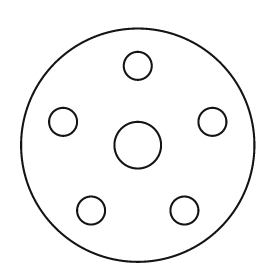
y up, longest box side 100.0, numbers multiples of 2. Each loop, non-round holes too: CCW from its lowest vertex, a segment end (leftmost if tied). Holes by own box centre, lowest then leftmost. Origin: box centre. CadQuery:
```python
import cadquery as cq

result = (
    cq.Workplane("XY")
    .moveTo(0.0, 0.0)
    .circle(50.0)
    .moveTo(-20.0, -28.0)
    .circle(6.0)
    .moveTo(20.0, -28.0)
    .circle(6.0)
    .moveTo(0.0, 0.0)
    .circle(10.0)
    .moveTo(-32.0, 10.0)
    .circle(6.0)
    .moveTo(32.0, 10.0)
    .circle(6.0)
    .moveTo(0.0, 34.0)
    .circle(6.0)
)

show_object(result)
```